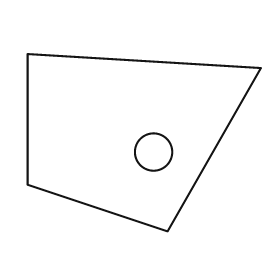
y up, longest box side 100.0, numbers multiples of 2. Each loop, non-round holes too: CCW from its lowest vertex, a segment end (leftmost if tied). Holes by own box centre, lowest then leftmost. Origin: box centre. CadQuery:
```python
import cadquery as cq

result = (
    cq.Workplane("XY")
    .moveTo(10.0, -38.0)
    .lineTo(50.0, 32.0)
    .lineTo(-50.0, 38.0)
    .lineTo(-50.0, -18.0)
    .close()
    .moveTo(4.0, -4.0)
    .circle(8.0)
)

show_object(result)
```